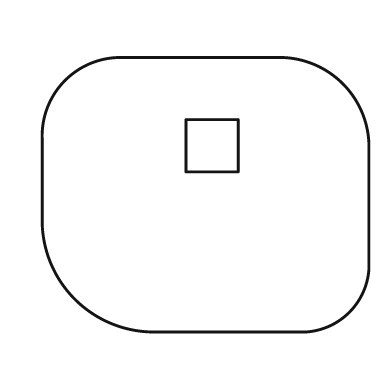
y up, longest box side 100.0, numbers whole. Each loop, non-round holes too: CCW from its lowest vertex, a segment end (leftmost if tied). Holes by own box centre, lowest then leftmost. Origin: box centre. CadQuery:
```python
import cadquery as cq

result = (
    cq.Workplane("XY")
    .moveTo(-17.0, -42.0)
    .lineTo(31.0, -42.0)
    .threePointArc((44.0, -36.0), (50.0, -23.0))
    .lineTo(50.0, 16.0)
    .threePointArc((42.0, 34.0), (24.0, 42.0))
    .lineTo(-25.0, 42.0)
    .threePointArc((-43.0, 35.0), (-50.0, 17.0))
    .lineTo(-50.0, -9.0)
    .threePointArc((-40.0, -32.0), (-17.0, -42.0))
    .close()
    .moveTo(-6.0, 7.0)
    .lineTo(10.0, 7.0)
    .lineTo(10.0, 23.0)
    .lineTo(-6.0, 23.0)
    .close()
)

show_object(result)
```